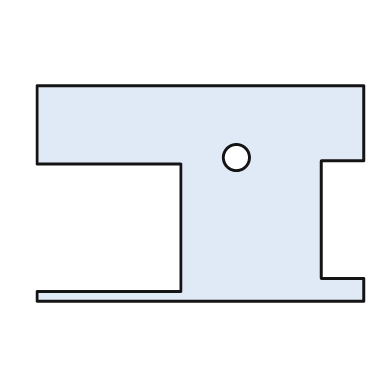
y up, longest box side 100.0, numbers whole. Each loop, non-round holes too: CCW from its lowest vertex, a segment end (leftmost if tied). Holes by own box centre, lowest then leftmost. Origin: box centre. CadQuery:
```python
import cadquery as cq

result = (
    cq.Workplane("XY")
    .moveTo(-50.0, -33.0)
    .lineTo(50.0, -33.0)
    .lineTo(50.0, -26.0)
    .lineTo(37.0, -26.0)
    .lineTo(37.0, 10.0)
    .lineTo(50.0, 10.0)
    .lineTo(50.0, 33.0)
    .lineTo(-50.0, 33.0)
    .lineTo(-50.0, 9.0)
    .lineTo(-6.0, 9.0)
    .lineTo(-6.0, -30.0)
    .lineTo(-50.0, -30.0)
    .close()
    .moveTo(11.0, 11.0)
    .circle(4.0)
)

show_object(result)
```